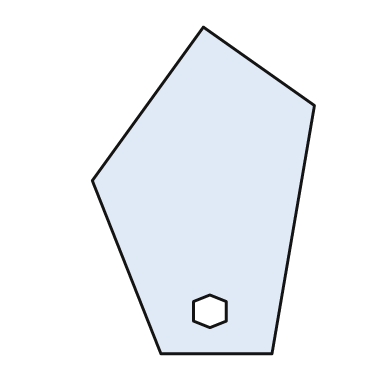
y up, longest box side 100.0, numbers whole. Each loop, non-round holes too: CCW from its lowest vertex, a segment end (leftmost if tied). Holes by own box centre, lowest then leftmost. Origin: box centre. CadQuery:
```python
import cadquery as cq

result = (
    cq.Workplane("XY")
    .moveTo(-13.0, -50.0)
    .lineTo(21.0, -50.0)
    .lineTo(34.0, 26.0)
    .lineTo(0.0, 50.0)
    .lineTo(-34.0, 3.0)
    .close()
    .moveTo(2.0, -42.0)
    .lineTo(7.0, -40.0)
    .lineTo(7.0, -34.0)
    .lineTo(2.0, -32.0)
    .lineTo(-3.0, -34.0)
    .lineTo(-3.0, -40.0)
    .close()
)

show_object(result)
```